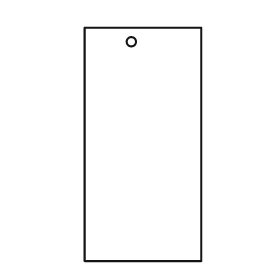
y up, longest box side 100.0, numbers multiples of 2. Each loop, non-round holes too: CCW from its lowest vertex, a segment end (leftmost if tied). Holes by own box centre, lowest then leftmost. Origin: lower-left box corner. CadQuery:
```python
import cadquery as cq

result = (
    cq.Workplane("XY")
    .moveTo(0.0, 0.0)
    .lineTo(50.0, 0.0)
    .lineTo(50.0, 100.0)
    .lineTo(0.0, 100.0)
    .close()
    .moveTo(20.0, 94.0)
    .circle(2.0)
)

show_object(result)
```